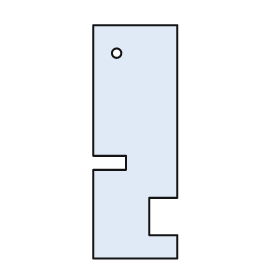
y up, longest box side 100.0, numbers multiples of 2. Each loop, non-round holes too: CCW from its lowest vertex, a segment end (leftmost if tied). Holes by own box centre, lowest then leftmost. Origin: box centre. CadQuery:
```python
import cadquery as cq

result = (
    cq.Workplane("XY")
    .moveTo(-18.0, -50.0)
    .lineTo(18.0, -50.0)
    .lineTo(18.0, -40.0)
    .lineTo(6.0, -40.0)
    .lineTo(6.0, -24.0)
    .lineTo(18.0, -24.0)
    .lineTo(18.0, 50.0)
    .lineTo(-18.0, 50.0)
    .lineTo(-18.0, -6.0)
    .lineTo(-4.0, -6.0)
    .lineTo(-4.0, -12.0)
    .lineTo(-18.0, -12.0)
    .close()
    .moveTo(-8.0, 38.0)
    .circle(2.0)
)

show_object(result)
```